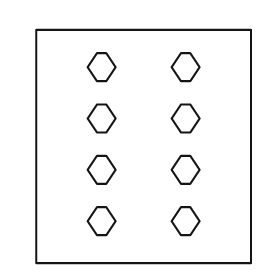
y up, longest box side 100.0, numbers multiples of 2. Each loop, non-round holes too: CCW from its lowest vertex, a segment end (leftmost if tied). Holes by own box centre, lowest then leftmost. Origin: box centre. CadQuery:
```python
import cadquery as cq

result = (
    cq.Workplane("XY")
    .moveTo(-46.0, -50.0)
    .lineTo(46.0, -50.0)
    .lineTo(46.0, 50.0)
    .lineTo(-46.0, 50.0)
    .close()
    .moveTo(-20.0, -38.0)
    .lineTo(-16.0, -38.0)
    .lineTo(-12.0, -32.0)
    .lineTo(-16.0, -26.0)
    .lineTo(-20.0, -26.0)
    .lineTo(-24.0, -32.0)
    .close()
    .moveTo(16.0, -38.0)
    .lineTo(20.0, -38.0)
    .lineTo(24.0, -32.0)
    .lineTo(20.0, -26.0)
    .lineTo(16.0, -26.0)
    .lineTo(12.0, -32.0)
    .close()
    .moveTo(-20.0, -16.0)
    .lineTo(-16.0, -16.0)
    .lineTo(-12.0, -10.0)
    .lineTo(-16.0, -4.0)
    .lineTo(-20.0, -4.0)
    .lineTo(-24.0, -10.0)
    .close()
    .moveTo(16.0, -16.0)
    .lineTo(20.0, -16.0)
    .lineTo(24.0, -10.0)
    .lineTo(20.0, -4.0)
    .lineTo(16.0, -4.0)
    .lineTo(12.0, -10.0)
    .close()
    .moveTo(-20.0, 6.0)
    .lineTo(-16.0, 6.0)
    .lineTo(-12.0, 12.0)
    .lineTo(-16.0, 18.0)
    .lineTo(-20.0, 18.0)
    .lineTo(-24.0, 12.0)
    .close()
    .moveTo(16.0, 6.0)
    .lineTo(20.0, 6.0)
    .lineTo(24.0, 12.0)
    .lineTo(20.0, 18.0)
    .lineTo(16.0, 18.0)
    .lineTo(12.0, 12.0)
    .close()
    .moveTo(-20.0, 28.0)
    .lineTo(-16.0, 28.0)
    .lineTo(-12.0, 34.0)
    .lineTo(-16.0, 40.0)
    .lineTo(-20.0, 40.0)
    .lineTo(-24.0, 34.0)
    .close()
    .moveTo(16.0, 28.0)
    .lineTo(20.0, 28.0)
    .lineTo(24.0, 34.0)
    .lineTo(20.0, 40.0)
    .lineTo(16.0, 40.0)
    .lineTo(12.0, 34.0)
    .close()
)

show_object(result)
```